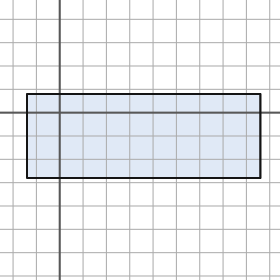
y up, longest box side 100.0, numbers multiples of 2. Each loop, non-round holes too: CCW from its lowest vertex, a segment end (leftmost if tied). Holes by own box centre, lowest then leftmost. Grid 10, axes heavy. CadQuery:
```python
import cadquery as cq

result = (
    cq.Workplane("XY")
    .moveTo(-14.0, -28.0)
    .lineTo(86.0, -28.0)
    .lineTo(86.0, 8.0)
    .lineTo(-14.0, 8.0)
    .close()
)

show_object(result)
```